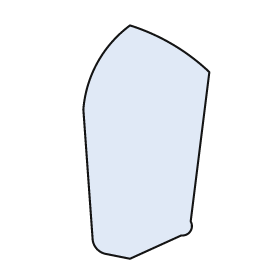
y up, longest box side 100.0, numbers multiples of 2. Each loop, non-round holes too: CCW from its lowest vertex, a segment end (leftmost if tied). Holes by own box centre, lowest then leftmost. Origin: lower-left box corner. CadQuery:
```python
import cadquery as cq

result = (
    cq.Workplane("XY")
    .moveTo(20.0, 0.0)
    .lineTo(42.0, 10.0)
    .threePointArc((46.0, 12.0), (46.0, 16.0))
    .lineTo(54.0, 80.0)
    .threePointArc((38.0, 92.0), (20.0, 100.0))
    .threePointArc((6.0, 84.0), (0.0, 64.0))
    .lineTo(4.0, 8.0)
    .threePointArc((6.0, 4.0), (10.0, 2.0))
    .close()
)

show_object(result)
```